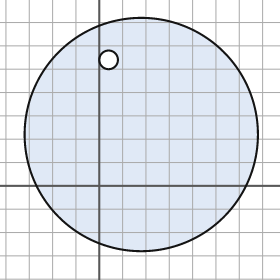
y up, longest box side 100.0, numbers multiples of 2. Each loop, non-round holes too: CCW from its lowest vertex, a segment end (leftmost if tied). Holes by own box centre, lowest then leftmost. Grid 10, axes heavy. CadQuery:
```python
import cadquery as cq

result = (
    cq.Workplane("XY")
    .moveTo(18.0, 22.0)
    .circle(50.0)
    .moveTo(4.0, 54.0)
    .circle(4.0)
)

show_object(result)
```